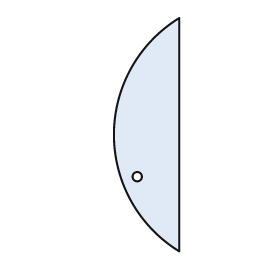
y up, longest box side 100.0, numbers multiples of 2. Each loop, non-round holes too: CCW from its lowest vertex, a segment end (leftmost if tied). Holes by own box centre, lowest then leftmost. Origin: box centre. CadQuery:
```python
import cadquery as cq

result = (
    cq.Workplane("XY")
    .moveTo(14.0, -50.0)
    .lineTo(14.0, 50.0)
    .threePointArc((-14.0, 0.0), (14.0, -50.0))
    .close()
    .moveTo(-4.0, -18.0)
    .circle(2.0)
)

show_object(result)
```